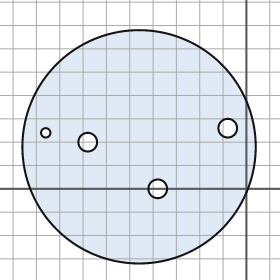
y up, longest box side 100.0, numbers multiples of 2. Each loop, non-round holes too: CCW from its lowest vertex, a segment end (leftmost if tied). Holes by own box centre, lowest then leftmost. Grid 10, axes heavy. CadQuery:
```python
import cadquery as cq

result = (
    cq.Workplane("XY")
    .moveTo(-46.0, 18.0)
    .circle(50.0)
    .moveTo(-38.0, 0.0)
    .circle(4.0)
    .moveTo(-68.0, 20.0)
    .circle(4.0)
    .moveTo(-86.0, 24.0)
    .circle(2.0)
    .moveTo(-8.0, 26.0)
    .circle(4.0)
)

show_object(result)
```